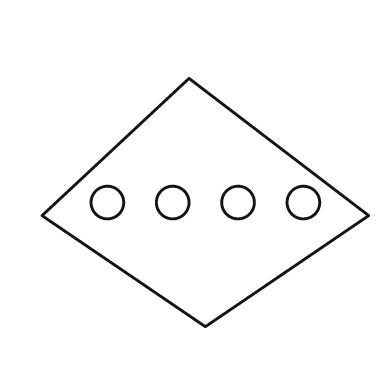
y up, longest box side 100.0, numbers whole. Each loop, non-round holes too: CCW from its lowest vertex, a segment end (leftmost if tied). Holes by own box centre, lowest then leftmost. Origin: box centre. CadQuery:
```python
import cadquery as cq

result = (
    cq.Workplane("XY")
    .moveTo(0.0, -38.0)
    .lineTo(50.0, -4.0)
    .lineTo(-5.0, 38.0)
    .lineTo(-50.0, -4.0)
    .close()
    .moveTo(-30.0, 0.0)
    .circle(5.0)
    .moveTo(-10.0, 0.0)
    .circle(5.0)
    .moveTo(10.0, 0.0)
    .circle(5.0)
    .moveTo(30.0, 0.0)
    .circle(5.0)
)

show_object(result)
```